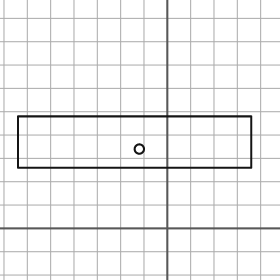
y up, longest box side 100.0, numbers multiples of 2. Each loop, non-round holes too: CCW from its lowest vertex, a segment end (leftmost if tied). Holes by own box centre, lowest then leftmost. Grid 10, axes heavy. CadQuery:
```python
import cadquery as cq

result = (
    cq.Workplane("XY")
    .moveTo(-64.0, 26.0)
    .lineTo(36.0, 26.0)
    .lineTo(36.0, 48.0)
    .lineTo(-64.0, 48.0)
    .close()
    .moveTo(-12.0, 34.0)
    .circle(2.0)
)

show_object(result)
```